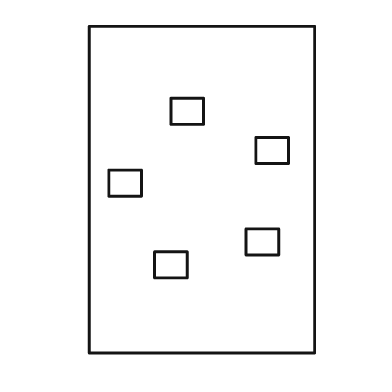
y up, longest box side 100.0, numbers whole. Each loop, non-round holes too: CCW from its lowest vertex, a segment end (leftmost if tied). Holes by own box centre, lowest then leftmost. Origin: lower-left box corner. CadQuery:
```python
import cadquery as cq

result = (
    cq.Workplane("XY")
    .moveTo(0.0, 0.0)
    .lineTo(69.0, 0.0)
    .lineTo(69.0, 100.0)
    .lineTo(0.0, 100.0)
    .close()
    .moveTo(20.0, 23.0)
    .lineTo(30.0, 23.0)
    .lineTo(30.0, 31.0)
    .lineTo(20.0, 31.0)
    .close()
    .moveTo(48.0, 30.0)
    .lineTo(58.0, 30.0)
    .lineTo(58.0, 38.0)
    .lineTo(48.0, 38.0)
    .close()
    .moveTo(6.0, 48.0)
    .lineTo(16.0, 48.0)
    .lineTo(16.0, 56.0)
    .lineTo(6.0, 56.0)
    .close()
    .moveTo(51.0, 58.0)
    .lineTo(61.0, 58.0)
    .lineTo(61.0, 66.0)
    .lineTo(51.0, 66.0)
    .close()
    .moveTo(25.0, 70.0)
    .lineTo(35.0, 70.0)
    .lineTo(35.0, 78.0)
    .lineTo(25.0, 78.0)
    .close()
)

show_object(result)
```